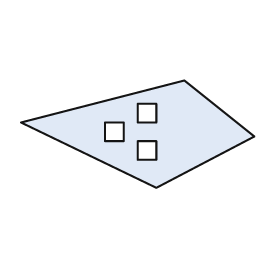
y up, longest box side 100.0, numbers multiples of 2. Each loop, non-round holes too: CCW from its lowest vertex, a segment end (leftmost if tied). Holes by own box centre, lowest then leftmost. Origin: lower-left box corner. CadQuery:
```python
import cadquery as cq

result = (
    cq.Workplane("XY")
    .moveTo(58.0, 0.0)
    .lineTo(100.0, 22.0)
    .lineTo(70.0, 46.0)
    .lineTo(0.0, 28.0)
    .close()
    .moveTo(50.0, 12.0)
    .lineTo(58.0, 12.0)
    .lineTo(58.0, 20.0)
    .lineTo(50.0, 20.0)
    .close()
    .moveTo(36.0, 20.0)
    .lineTo(44.0, 20.0)
    .lineTo(44.0, 28.0)
    .lineTo(36.0, 28.0)
    .close()
    .moveTo(50.0, 28.0)
    .lineTo(58.0, 28.0)
    .lineTo(58.0, 36.0)
    .lineTo(50.0, 36.0)
    .close()
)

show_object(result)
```